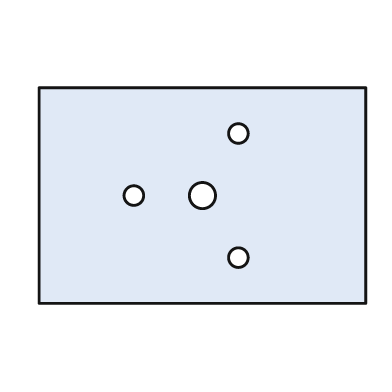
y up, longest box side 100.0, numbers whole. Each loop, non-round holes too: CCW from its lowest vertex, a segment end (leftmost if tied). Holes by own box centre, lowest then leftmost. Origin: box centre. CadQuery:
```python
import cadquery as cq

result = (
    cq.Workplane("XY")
    .moveTo(-50.0, -33.0)
    .lineTo(50.0, -33.0)
    .lineTo(50.0, 33.0)
    .lineTo(-50.0, 33.0)
    .close()
    .moveTo(11.0, -19.0)
    .circle(3.0)
    .moveTo(-21.0, 0.0)
    .circle(3.0)
    .moveTo(0.0, 0.0)
    .circle(4.0)
    .moveTo(11.0, 19.0)
    .circle(3.0)
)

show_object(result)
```